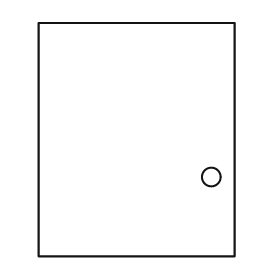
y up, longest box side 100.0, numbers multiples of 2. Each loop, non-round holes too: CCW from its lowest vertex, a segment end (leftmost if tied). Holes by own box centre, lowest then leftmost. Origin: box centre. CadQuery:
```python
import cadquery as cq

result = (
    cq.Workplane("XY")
    .moveTo(-42.0, -50.0)
    .lineTo(42.0, -50.0)
    .lineTo(42.0, 50.0)
    .lineTo(-42.0, 50.0)
    .close()
    .moveTo(32.0, -16.0)
    .circle(4.0)
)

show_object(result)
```